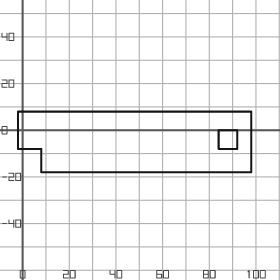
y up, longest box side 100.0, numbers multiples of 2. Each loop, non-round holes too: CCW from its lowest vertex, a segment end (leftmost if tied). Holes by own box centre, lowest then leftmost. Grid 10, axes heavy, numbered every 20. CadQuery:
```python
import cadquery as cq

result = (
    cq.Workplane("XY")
    .moveTo(8.0, -18.0)
    .lineTo(98.0, -18.0)
    .lineTo(98.0, 8.0)
    .lineTo(-2.0, 8.0)
    .lineTo(-2.0, -8.0)
    .lineTo(8.0, -8.0)
    .close()
    .moveTo(84.0, -8.0)
    .lineTo(92.0, -8.0)
    .lineTo(92.0, 0.0)
    .lineTo(84.0, 0.0)
    .close()
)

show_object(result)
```